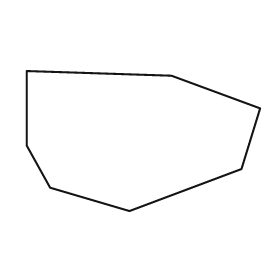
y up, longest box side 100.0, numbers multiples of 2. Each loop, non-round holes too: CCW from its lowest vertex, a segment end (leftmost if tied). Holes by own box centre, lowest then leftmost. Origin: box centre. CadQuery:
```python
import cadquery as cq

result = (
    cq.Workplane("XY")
    .moveTo(-6.0, -30.0)
    .lineTo(42.0, -12.0)
    .lineTo(50.0, 14.0)
    .lineTo(12.0, 28.0)
    .lineTo(-50.0, 30.0)
    .lineTo(-50.0, -2.0)
    .lineTo(-40.0, -20.0)
    .close()
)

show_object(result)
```